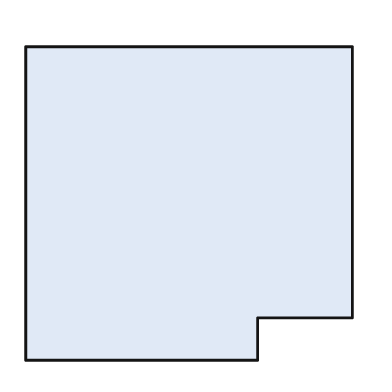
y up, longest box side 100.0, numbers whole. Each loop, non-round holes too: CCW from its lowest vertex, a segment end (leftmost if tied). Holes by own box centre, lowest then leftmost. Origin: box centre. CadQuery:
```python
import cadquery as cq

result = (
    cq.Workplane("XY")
    .moveTo(-50.0, -48.0)
    .lineTo(21.0, -48.0)
    .lineTo(21.0, -35.0)
    .lineTo(50.0, -35.0)
    .lineTo(50.0, 48.0)
    .lineTo(-50.0, 48.0)
    .close()
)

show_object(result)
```